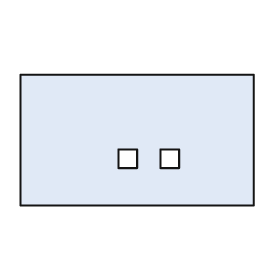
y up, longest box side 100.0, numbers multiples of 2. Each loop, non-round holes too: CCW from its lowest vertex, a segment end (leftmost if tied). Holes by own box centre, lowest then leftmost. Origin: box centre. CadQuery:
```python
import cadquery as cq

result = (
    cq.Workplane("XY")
    .moveTo(-50.0, -28.0)
    .lineTo(50.0, -28.0)
    .lineTo(50.0, 28.0)
    .lineTo(-50.0, 28.0)
    .close()
    .moveTo(-8.0, -12.0)
    .lineTo(0.0, -12.0)
    .lineTo(0.0, -4.0)
    .lineTo(-8.0, -4.0)
    .close()
    .moveTo(10.0, -12.0)
    .lineTo(18.0, -12.0)
    .lineTo(18.0, -4.0)
    .lineTo(10.0, -4.0)
    .close()
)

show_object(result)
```